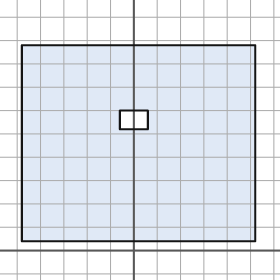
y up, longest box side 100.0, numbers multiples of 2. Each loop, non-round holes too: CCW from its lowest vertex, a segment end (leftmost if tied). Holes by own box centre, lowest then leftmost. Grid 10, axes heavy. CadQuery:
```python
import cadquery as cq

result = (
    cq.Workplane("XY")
    .moveTo(-48.0, 4.0)
    .lineTo(52.0, 4.0)
    .lineTo(52.0, 88.0)
    .lineTo(-48.0, 88.0)
    .close()
    .moveTo(-6.0, 52.0)
    .lineTo(6.0, 52.0)
    .lineTo(6.0, 60.0)
    .lineTo(-6.0, 60.0)
    .close()
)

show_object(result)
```